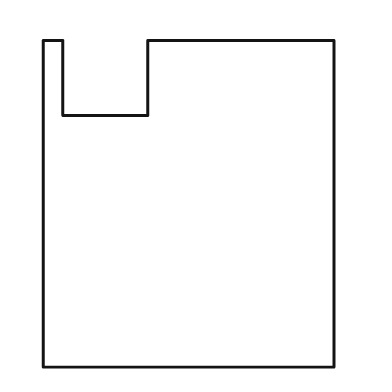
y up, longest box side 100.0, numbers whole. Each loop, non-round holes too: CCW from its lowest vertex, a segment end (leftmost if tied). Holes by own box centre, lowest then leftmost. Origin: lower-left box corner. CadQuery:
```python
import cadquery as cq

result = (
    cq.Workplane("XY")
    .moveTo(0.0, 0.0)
    .lineTo(89.0, 0.0)
    .lineTo(89.0, 100.0)
    .lineTo(32.0, 100.0)
    .lineTo(32.0, 77.0)
    .lineTo(6.0, 77.0)
    .lineTo(6.0, 100.0)
    .lineTo(0.0, 100.0)
    .close()
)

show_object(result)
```